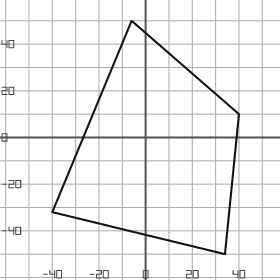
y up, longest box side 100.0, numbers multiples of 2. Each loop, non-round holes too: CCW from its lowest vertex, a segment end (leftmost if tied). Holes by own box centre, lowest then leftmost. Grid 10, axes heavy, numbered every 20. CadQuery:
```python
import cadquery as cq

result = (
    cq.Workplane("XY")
    .moveTo(34.0, -50.0)
    .lineTo(40.0, 10.0)
    .lineTo(-6.0, 50.0)
    .lineTo(-40.0, -32.0)
    .close()
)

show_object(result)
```